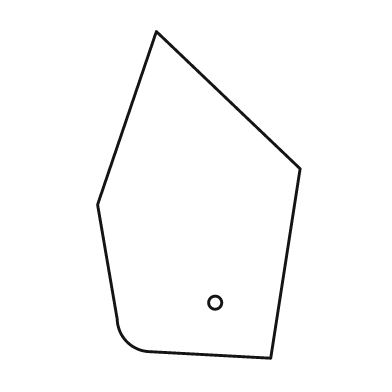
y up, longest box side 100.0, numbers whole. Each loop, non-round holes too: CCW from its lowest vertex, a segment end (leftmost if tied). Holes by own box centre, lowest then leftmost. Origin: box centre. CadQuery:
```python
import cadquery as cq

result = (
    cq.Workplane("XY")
    .moveTo(22.0, -50.0)
    .lineTo(31.0, 8.0)
    .lineTo(-13.0, 50.0)
    .lineTo(-31.0, -3.0)
    .lineTo(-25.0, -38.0)
    .threePointArc((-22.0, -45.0), (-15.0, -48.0))
    .close()
    .moveTo(5.0, -33.0)
    .circle(2.0)
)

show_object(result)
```